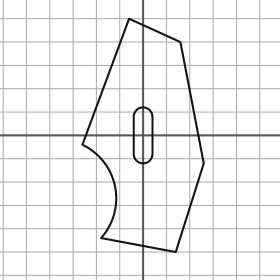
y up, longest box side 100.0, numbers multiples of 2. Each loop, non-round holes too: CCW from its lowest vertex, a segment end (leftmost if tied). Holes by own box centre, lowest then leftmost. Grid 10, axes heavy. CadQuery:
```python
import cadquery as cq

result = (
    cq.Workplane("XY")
    .moveTo(14.0, -50.0)
    .lineTo(26.0, -12.0)
    .lineTo(16.0, 40.0)
    .lineTo(-6.0, 50.0)
    .lineTo(-26.0, -4.0)
    .threePointArc((-12.0, -22.0), (-18.0, -44.0))
    .close()
    .moveTo(-4.0, -8.0)
    .threePointArc((0.0, -12.0), (4.0, -8.0))
    .lineTo(4.0, 8.0)
    .threePointArc((0.0, 12.0), (-4.0, 8.0))
    .close()
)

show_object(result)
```